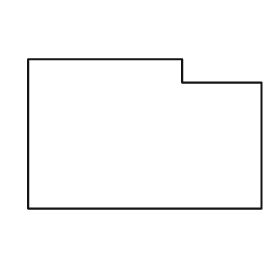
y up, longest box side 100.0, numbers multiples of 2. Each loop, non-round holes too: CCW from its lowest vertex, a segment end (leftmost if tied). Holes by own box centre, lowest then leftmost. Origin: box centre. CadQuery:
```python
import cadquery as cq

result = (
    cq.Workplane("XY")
    .moveTo(-50.0, -32.0)
    .lineTo(50.0, -32.0)
    .lineTo(50.0, 22.0)
    .lineTo(16.0, 22.0)
    .lineTo(16.0, 32.0)
    .lineTo(-50.0, 32.0)
    .close()
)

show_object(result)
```